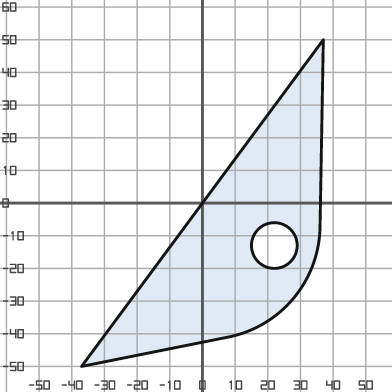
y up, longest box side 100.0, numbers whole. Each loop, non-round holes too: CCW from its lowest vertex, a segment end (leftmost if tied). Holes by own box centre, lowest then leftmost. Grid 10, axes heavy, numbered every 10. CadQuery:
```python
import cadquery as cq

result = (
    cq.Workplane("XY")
    .moveTo(-37.0, -50.0)
    .lineTo(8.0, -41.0)
    .threePointArc((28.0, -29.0), (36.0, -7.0))
    .lineTo(37.0, 50.0)
    .close()
    .moveTo(22.0, -13.0)
    .circle(7.0)
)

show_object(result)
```